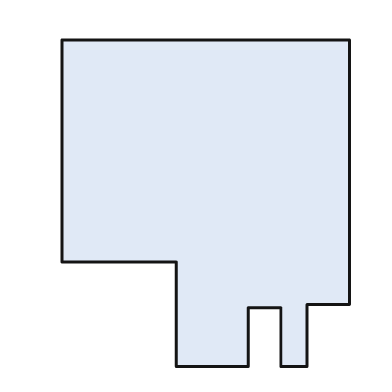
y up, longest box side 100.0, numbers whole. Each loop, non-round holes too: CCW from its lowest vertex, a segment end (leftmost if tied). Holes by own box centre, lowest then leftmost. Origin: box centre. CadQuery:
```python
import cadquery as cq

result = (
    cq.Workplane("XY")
    .moveTo(-9.0, -50.0)
    .lineTo(13.0, -50.0)
    .lineTo(13.0, -32.0)
    .lineTo(23.0, -32.0)
    .lineTo(23.0, -50.0)
    .lineTo(31.0, -50.0)
    .lineTo(31.0, -31.0)
    .lineTo(44.0, -31.0)
    .lineTo(44.0, 50.0)
    .lineTo(-44.0, 50.0)
    .lineTo(-44.0, -18.0)
    .lineTo(-9.0, -18.0)
    .close()
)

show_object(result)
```